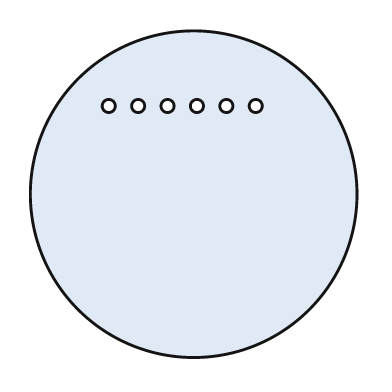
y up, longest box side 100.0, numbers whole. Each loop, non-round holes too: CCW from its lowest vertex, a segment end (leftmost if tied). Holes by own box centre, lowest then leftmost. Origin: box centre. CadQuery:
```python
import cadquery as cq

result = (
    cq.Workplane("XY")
    .moveTo(0.0, 0.0)
    .circle(50.0)
    .moveTo(-26.0, 27.0)
    .circle(2.0)
    .moveTo(-17.0, 27.0)
    .circle(2.0)
    .moveTo(-8.0, 27.0)
    .circle(2.0)
    .moveTo(1.0, 27.0)
    .circle(2.0)
    .moveTo(10.0, 27.0)
    .circle(2.0)
    .moveTo(19.0, 27.0)
    .circle(2.0)
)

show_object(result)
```